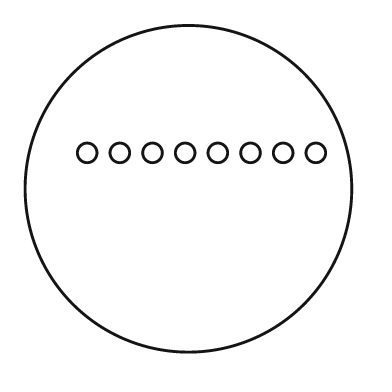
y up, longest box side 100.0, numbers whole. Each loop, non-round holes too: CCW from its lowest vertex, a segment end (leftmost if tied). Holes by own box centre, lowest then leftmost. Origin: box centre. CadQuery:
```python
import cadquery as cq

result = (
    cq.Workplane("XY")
    .moveTo(0.0, 0.0)
    .circle(50.0)
    .moveTo(-31.0, 11.0)
    .circle(3.0)
    .moveTo(-21.0, 11.0)
    .circle(3.0)
    .moveTo(-11.0, 11.0)
    .circle(3.0)
    .moveTo(-1.0, 11.0)
    .circle(3.0)
    .moveTo(9.0, 11.0)
    .circle(3.0)
    .moveTo(19.0, 11.0)
    .circle(3.0)
    .moveTo(29.0, 11.0)
    .circle(3.0)
    .moveTo(39.0, 11.0)
    .circle(3.0)
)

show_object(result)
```